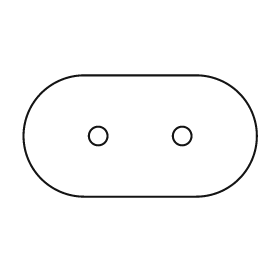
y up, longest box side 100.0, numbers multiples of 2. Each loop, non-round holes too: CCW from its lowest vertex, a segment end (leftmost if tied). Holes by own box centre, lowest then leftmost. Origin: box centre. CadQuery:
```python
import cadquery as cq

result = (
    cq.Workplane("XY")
    .moveTo(-24.0, -26.0)
    .lineTo(24.0, -26.0)
    .threePointArc((50.0, 0.0), (24.0, 26.0))
    .lineTo(-24.0, 26.0)
    .threePointArc((-50.0, 0.0), (-24.0, -26.0))
    .close()
    .moveTo(-18.0, 0.0)
    .circle(4.0)
    .moveTo(18.0, 0.0)
    .circle(4.0)
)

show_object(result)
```